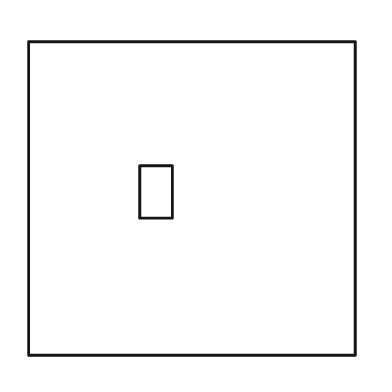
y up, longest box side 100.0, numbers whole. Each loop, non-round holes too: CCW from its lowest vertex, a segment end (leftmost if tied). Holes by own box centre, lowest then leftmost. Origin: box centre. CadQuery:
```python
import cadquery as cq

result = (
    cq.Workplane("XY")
    .moveTo(-50.0, -48.0)
    .lineTo(50.0, -48.0)
    .lineTo(50.0, 48.0)
    .lineTo(-50.0, 48.0)
    .close()
    .moveTo(-16.0, -6.0)
    .lineTo(-6.0, -6.0)
    .lineTo(-6.0, 10.0)
    .lineTo(-16.0, 10.0)
    .close()
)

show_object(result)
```